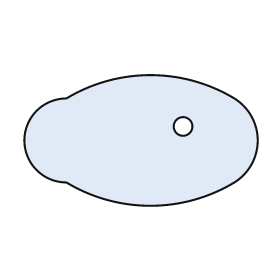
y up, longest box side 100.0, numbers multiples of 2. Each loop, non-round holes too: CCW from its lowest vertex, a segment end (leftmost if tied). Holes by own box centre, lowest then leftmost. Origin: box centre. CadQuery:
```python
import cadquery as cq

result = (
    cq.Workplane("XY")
    .moveTo(-32.0, -18.0)
    .threePointArc((4.0, -28.0), (40.0, -18.0))
    .threePointArc((50.0, 0.0), (40.0, 18.0))
    .threePointArc((4.0, 28.0), (-32.0, 18.0))
    .threePointArc((-50.0, 0.0), (-32.0, -18.0))
    .close()
    .moveTo(18.0, 6.0)
    .circle(4.0)
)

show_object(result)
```